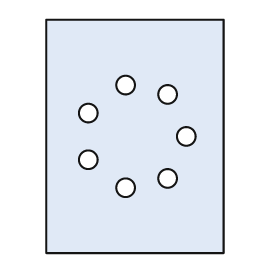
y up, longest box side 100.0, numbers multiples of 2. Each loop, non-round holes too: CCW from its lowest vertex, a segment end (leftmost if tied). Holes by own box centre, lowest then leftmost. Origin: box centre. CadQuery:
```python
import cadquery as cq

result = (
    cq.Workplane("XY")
    .moveTo(-38.0, -50.0)
    .lineTo(38.0, -50.0)
    .lineTo(38.0, 50.0)
    .lineTo(-38.0, 50.0)
    .close()
    .moveTo(-4.0, -22.0)
    .circle(4.0)
    .moveTo(14.0, -18.0)
    .circle(4.0)
    .moveTo(-20.0, -10.0)
    .circle(4.0)
    .moveTo(22.0, 0.0)
    .circle(4.0)
    .moveTo(-20.0, 10.0)
    .circle(4.0)
    .moveTo(14.0, 18.0)
    .circle(4.0)
    .moveTo(-4.0, 22.0)
    .circle(4.0)
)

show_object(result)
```